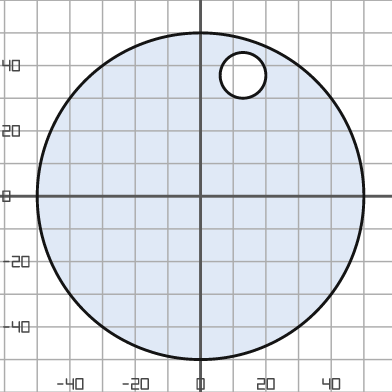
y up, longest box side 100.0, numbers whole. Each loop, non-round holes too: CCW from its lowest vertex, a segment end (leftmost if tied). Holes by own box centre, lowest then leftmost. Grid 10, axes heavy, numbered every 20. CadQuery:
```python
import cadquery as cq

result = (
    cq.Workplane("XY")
    .moveTo(0.0, 0.0)
    .circle(50.0)
    .moveTo(13.0, 37.0)
    .circle(7.0)
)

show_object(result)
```